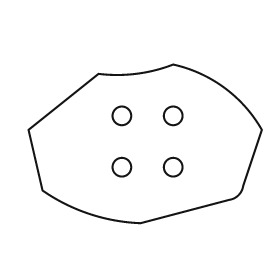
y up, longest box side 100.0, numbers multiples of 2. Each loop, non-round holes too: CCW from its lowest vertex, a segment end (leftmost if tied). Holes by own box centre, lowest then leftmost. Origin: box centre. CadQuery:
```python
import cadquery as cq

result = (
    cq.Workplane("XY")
    .moveTo(-2.0, -34.0)
    .lineTo(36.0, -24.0)
    .threePointArc((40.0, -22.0), (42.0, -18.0))
    .lineTo(50.0, 6.0)
    .threePointArc((34.0, 24.0), (12.0, 34.0))
    .threePointArc((-4.0, 30.0), (-20.0, 30.0))
    .lineTo(-50.0, 6.0)
    .lineTo(-44.0, -20.0)
    .threePointArc((-24.0, -30.0), (-2.0, -34.0))
    .close()
    .moveTo(-10.0, -10.0)
    .circle(4.0)
    .moveTo(12.0, -10.0)
    .circle(4.0)
    .moveTo(-10.0, 12.0)
    .circle(4.0)
    .moveTo(12.0, 12.0)
    .circle(4.0)
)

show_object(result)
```